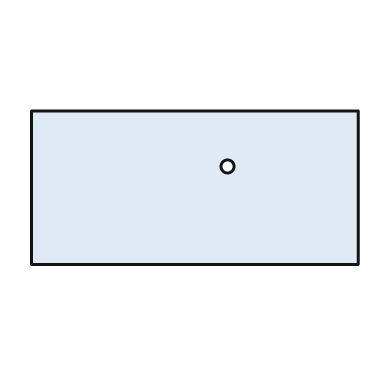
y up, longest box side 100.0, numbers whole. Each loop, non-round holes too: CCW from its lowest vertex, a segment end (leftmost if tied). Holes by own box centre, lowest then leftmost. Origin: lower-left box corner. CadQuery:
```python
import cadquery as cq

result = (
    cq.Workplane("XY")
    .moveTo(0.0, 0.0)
    .lineTo(100.0, 0.0)
    .lineTo(100.0, 47.0)
    .lineTo(0.0, 47.0)
    .close()
    .moveTo(60.0, 30.0)
    .circle(2.0)
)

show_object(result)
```